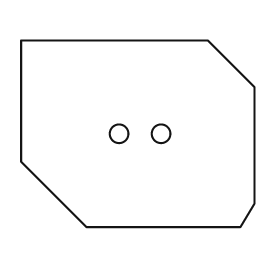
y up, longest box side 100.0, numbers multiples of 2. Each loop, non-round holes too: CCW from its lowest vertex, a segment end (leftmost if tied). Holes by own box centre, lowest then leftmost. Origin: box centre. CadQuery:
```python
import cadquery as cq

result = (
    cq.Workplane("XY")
    .moveTo(-22.0, -40.0)
    .lineTo(44.0, -40.0)
    .lineTo(50.0, -30.0)
    .lineTo(50.0, 20.0)
    .lineTo(30.0, 40.0)
    .lineTo(-50.0, 40.0)
    .lineTo(-50.0, -12.0)
    .close()
    .moveTo(-8.0, 0.0)
    .circle(4.0)
    .moveTo(10.0, 0.0)
    .circle(4.0)
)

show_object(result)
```